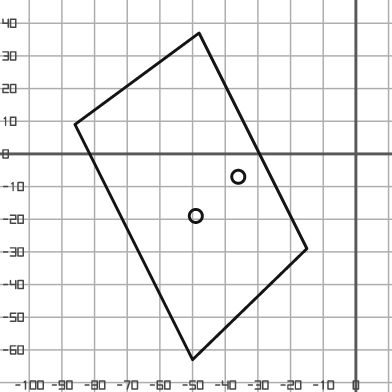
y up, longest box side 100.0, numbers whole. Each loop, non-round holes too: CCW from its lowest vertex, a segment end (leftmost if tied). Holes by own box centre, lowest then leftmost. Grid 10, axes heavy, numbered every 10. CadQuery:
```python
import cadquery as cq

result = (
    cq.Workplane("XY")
    .moveTo(-50.0, -63.0)
    .lineTo(-15.0, -29.0)
    .lineTo(-48.0, 37.0)
    .lineTo(-86.0, 9.0)
    .close()
    .moveTo(-49.0, -19.0)
    .circle(2.0)
    .moveTo(-36.0, -7.0)
    .circle(2.0)
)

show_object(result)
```